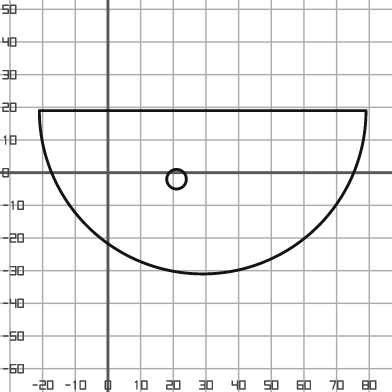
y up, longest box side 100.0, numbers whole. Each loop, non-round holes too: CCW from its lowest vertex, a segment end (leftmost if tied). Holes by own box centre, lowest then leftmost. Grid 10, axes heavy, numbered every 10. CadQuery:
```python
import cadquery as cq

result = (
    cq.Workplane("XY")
    .moveTo(-21.0, 19.0)
    .threePointArc((29.0, -31.0), (79.0, 19.0))
    .close()
    .moveTo(21.0, -2.0)
    .circle(3.0)
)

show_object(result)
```